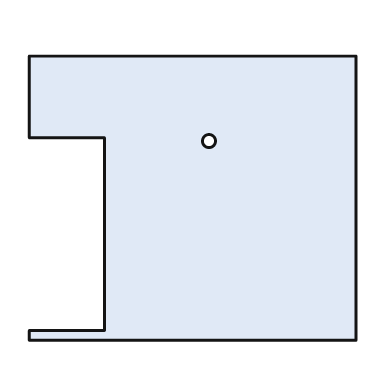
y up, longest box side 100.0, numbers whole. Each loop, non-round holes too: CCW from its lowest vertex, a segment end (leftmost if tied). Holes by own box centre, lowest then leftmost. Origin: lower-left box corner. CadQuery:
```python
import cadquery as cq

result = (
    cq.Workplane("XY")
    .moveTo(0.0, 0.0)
    .lineTo(100.0, 0.0)
    .lineTo(100.0, 87.0)
    .lineTo(0.0, 87.0)
    .lineTo(0.0, 62.0)
    .lineTo(23.0, 62.0)
    .lineTo(23.0, 3.0)
    .lineTo(0.0, 3.0)
    .close()
    .moveTo(55.0, 61.0)
    .circle(2.0)
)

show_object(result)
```